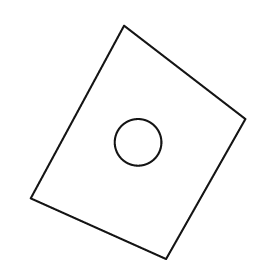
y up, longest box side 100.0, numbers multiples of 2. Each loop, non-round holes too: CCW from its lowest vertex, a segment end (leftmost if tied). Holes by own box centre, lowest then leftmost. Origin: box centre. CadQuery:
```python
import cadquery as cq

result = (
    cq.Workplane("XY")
    .moveTo(12.0, -50.0)
    .lineTo(46.0, 10.0)
    .lineTo(-6.0, 50.0)
    .lineTo(-46.0, -24.0)
    .close()
    .moveTo(0.0, 0.0)
    .circle(10.0)
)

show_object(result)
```